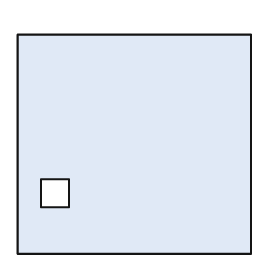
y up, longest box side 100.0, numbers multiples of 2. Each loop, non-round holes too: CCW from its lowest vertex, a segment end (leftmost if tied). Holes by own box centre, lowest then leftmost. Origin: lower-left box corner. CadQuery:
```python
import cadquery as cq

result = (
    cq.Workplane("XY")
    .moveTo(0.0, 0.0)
    .lineTo(100.0, 0.0)
    .lineTo(100.0, 94.0)
    .lineTo(0.0, 94.0)
    .close()
    .moveTo(10.0, 20.0)
    .lineTo(22.0, 20.0)
    .lineTo(22.0, 32.0)
    .lineTo(10.0, 32.0)
    .close()
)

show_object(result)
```